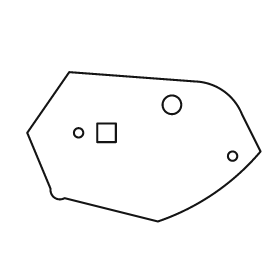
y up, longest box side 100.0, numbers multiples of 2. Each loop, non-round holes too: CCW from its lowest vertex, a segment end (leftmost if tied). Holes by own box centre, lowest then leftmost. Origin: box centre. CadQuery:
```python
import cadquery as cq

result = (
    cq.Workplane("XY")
    .moveTo(6.0, -32.0)
    .threePointArc((30.0, -20.0), (50.0, -2.0))
    .lineTo(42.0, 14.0)
    .threePointArc((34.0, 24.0), (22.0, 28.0))
    .lineTo(-32.0, 32.0)
    .lineTo(-50.0, 6.0)
    .lineTo(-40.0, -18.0)
    .threePointArc((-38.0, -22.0), (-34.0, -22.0))
    .close()
    .moveTo(38.0, -4.0)
    .circle(2.0)
    .moveTo(-28.0, 6.0)
    .circle(2.0)
    .moveTo(-20.0, 2.0)
    .lineTo(-12.0, 2.0)
    .lineTo(-12.0, 10.0)
    .lineTo(-20.0, 10.0)
    .close()
    .moveTo(12.0, 18.0)
    .circle(4.0)
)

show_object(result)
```